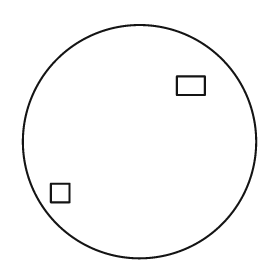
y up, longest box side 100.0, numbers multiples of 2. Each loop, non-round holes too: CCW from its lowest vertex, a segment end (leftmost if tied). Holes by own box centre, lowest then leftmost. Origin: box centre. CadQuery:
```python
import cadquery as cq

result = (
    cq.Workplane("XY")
    .moveTo(0.0, 0.0)
    .circle(50.0)
    .moveTo(-38.0, -26.0)
    .lineTo(-30.0, -26.0)
    .lineTo(-30.0, -18.0)
    .lineTo(-38.0, -18.0)
    .close()
    .moveTo(16.0, 20.0)
    .lineTo(28.0, 20.0)
    .lineTo(28.0, 28.0)
    .lineTo(16.0, 28.0)
    .close()
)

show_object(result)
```